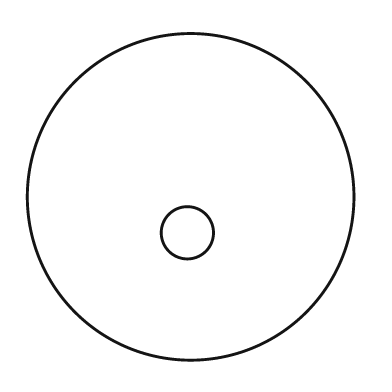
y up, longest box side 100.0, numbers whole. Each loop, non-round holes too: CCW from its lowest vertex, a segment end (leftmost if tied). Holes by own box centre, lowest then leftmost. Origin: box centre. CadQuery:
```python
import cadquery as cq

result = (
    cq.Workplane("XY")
    .moveTo(0.0, 0.0)
    .circle(50.0)
    .moveTo(-1.0, -11.0)
    .circle(8.0)
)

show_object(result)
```